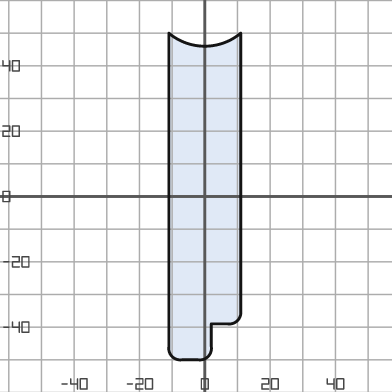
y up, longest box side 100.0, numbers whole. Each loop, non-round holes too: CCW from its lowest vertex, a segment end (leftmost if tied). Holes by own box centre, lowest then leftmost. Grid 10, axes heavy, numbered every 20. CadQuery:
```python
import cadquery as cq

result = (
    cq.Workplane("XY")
    .moveTo(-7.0, -50.0)
    .lineTo(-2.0, -50.0)
    .threePointArc((1.0, -49.0), (2.0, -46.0))
    .lineTo(2.0, -39.0)
    .lineTo(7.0, -39.0)
    .threePointArc((10.0, -38.0), (11.0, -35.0))
    .lineTo(11.0, 50.0)
    .threePointArc((0.0, 46.0), (-11.0, 50.0))
    .lineTo(-11.0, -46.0)
    .threePointArc((-10.0, -49.0), (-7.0, -50.0))
    .close()
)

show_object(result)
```